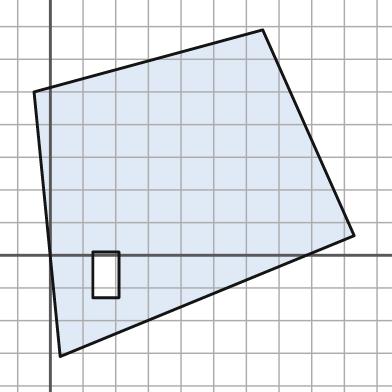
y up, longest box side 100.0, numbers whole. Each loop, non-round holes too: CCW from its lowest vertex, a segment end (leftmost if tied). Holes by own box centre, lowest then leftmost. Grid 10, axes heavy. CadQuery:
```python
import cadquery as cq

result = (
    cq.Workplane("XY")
    .moveTo(3.0, -31.0)
    .lineTo(93.0, 6.0)
    .lineTo(65.0, 69.0)
    .lineTo(-5.0, 50.0)
    .close()
    .moveTo(13.0, -13.0)
    .lineTo(21.0, -13.0)
    .lineTo(21.0, 1.0)
    .lineTo(13.0, 1.0)
    .close()
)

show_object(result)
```